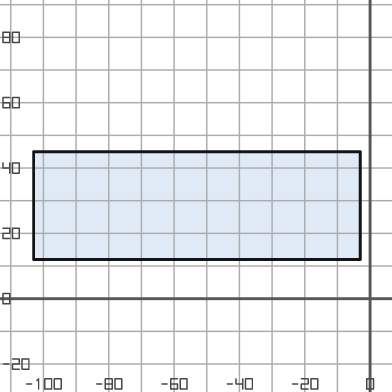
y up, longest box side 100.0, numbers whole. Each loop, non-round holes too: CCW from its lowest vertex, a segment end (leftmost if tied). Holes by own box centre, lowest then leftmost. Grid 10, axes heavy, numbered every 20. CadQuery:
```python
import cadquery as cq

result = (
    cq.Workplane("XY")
    .moveTo(-103.0, 12.0)
    .lineTo(-3.0, 12.0)
    .lineTo(-3.0, 45.0)
    .lineTo(-103.0, 45.0)
    .close()
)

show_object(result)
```